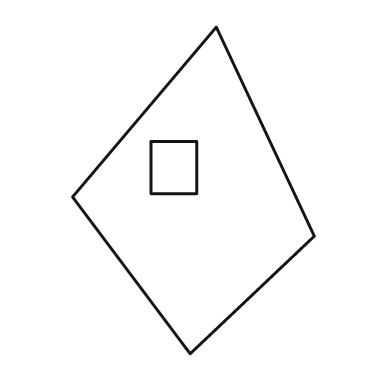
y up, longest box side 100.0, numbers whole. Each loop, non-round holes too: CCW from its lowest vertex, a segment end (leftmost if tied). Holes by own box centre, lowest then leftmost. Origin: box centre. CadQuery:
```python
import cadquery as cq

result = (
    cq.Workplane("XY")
    .moveTo(-1.0, -50.0)
    .lineTo(37.0, -14.0)
    .lineTo(7.0, 50.0)
    .lineTo(-37.0, -2.0)
    .close()
    .moveTo(-13.0, -1.0)
    .lineTo(1.0, -1.0)
    .lineTo(1.0, 15.0)
    .lineTo(-13.0, 15.0)
    .close()
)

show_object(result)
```